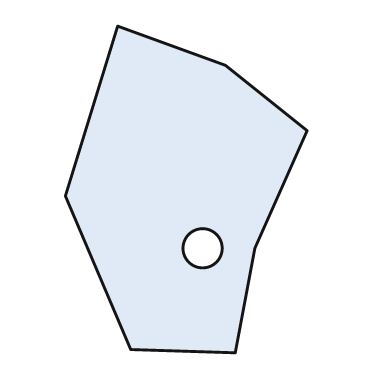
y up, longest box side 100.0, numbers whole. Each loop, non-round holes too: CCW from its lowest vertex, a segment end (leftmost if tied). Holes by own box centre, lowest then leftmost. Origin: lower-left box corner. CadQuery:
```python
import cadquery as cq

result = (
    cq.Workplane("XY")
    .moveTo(52.0, 0.0)
    .lineTo(58.0, 32.0)
    .lineTo(74.0, 68.0)
    .lineTo(49.0, 88.0)
    .lineTo(16.0, 100.0)
    .lineTo(0.0, 48.0)
    .lineTo(20.0, 1.0)
    .close()
    .moveTo(42.0, 32.0)
    .circle(6.0)
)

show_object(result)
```